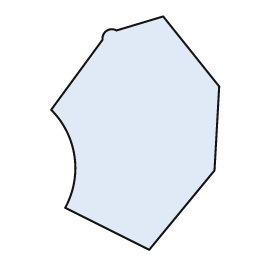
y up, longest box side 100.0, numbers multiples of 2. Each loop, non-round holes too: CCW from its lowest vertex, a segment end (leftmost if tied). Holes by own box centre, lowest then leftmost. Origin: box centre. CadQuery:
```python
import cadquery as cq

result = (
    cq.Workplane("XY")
    .moveTo(6.0, -50.0)
    .lineTo(34.0, -16.0)
    .lineTo(36.0, 20.0)
    .lineTo(12.0, 50.0)
    .lineTo(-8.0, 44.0)
    .threePointArc((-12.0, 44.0), (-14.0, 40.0))
    .lineTo(-36.0, 10.0)
    .threePointArc((-26.0, -10.0), (-30.0, -32.0))
    .close()
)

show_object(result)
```